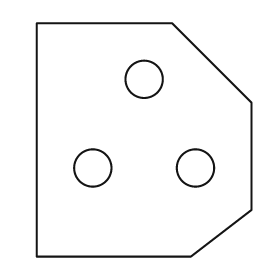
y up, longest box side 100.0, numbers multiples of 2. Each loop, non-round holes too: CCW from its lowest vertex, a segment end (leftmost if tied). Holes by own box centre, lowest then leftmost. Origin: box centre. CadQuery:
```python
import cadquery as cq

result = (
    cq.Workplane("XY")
    .moveTo(-46.0, -50.0)
    .lineTo(20.0, -50.0)
    .lineTo(46.0, -30.0)
    .lineTo(46.0, 16.0)
    .lineTo(12.0, 50.0)
    .lineTo(-46.0, 50.0)
    .close()
    .moveTo(-22.0, -12.0)
    .circle(8.0)
    .moveTo(22.0, -12.0)
    .circle(8.0)
    .moveTo(0.0, 26.0)
    .circle(8.0)
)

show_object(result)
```